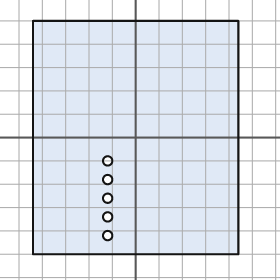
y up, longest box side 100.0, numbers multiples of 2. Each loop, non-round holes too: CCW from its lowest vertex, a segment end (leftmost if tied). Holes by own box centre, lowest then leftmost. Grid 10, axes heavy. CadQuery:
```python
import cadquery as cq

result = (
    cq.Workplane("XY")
    .moveTo(-44.0, -50.0)
    .lineTo(44.0, -50.0)
    .lineTo(44.0, 50.0)
    .lineTo(-44.0, 50.0)
    .close()
    .moveTo(-12.0, -42.0)
    .circle(2.0)
    .moveTo(-12.0, -34.0)
    .circle(2.0)
    .moveTo(-12.0, -26.0)
    .circle(2.0)
    .moveTo(-12.0, -18.0)
    .circle(2.0)
    .moveTo(-12.0, -10.0)
    .circle(2.0)
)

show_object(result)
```